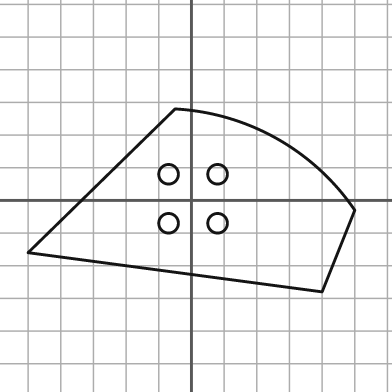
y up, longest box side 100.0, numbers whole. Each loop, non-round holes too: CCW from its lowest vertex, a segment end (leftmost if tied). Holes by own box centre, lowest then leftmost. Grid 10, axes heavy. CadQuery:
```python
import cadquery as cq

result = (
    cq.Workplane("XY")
    .moveTo(40.0, -28.0)
    .lineTo(50.0, -3.0)
    .threePointArc((26.0, 19.0), (-5.0, 28.0))
    .lineTo(-50.0, -16.0)
    .close()
    .moveTo(-7.0, -7.0)
    .circle(3.0)
    .moveTo(8.0, -7.0)
    .circle(3.0)
    .moveTo(-7.0, 8.0)
    .circle(3.0)
    .moveTo(8.0, 8.0)
    .circle(3.0)
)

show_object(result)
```